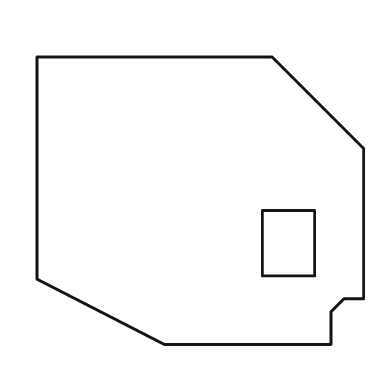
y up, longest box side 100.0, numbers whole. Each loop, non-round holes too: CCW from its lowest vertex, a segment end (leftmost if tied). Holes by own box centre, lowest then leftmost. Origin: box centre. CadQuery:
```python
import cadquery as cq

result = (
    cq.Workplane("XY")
    .moveTo(-11.0, -44.0)
    .lineTo(40.0, -44.0)
    .lineTo(40.0, -34.0)
    .lineTo(44.0, -30.0)
    .lineTo(50.0, -30.0)
    .lineTo(50.0, 16.0)
    .lineTo(22.0, 44.0)
    .lineTo(-50.0, 44.0)
    .lineTo(-50.0, -24.0)
    .close()
    .moveTo(19.0, -23.0)
    .lineTo(35.0, -23.0)
    .lineTo(35.0, -3.0)
    .lineTo(19.0, -3.0)
    .close()
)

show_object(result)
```